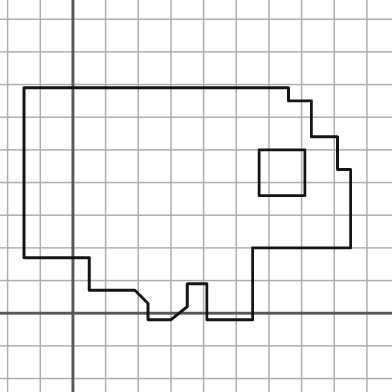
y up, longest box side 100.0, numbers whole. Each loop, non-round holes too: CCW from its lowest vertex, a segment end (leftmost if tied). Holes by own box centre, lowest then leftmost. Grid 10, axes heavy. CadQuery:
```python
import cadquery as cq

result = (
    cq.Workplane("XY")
    .moveTo(23.0, -2.0)
    .lineTo(30.0, -2.0)
    .lineTo(35.0, 2.0)
    .lineTo(35.0, 9.0)
    .lineTo(41.0, 9.0)
    .lineTo(41.0, -2.0)
    .lineTo(55.0, -2.0)
    .lineTo(55.0, 20.0)
    .lineTo(85.0, 20.0)
    .lineTo(85.0, 44.0)
    .lineTo(81.0, 44.0)
    .lineTo(81.0, 54.0)
    .lineTo(73.0, 54.0)
    .lineTo(73.0, 65.0)
    .lineTo(66.0, 65.0)
    .lineTo(66.0, 69.0)
    .lineTo(-15.0, 69.0)
    .lineTo(-15.0, 17.0)
    .lineTo(5.0, 17.0)
    .lineTo(5.0, 7.0)
    .lineTo(19.0, 7.0)
    .lineTo(23.0, 3.0)
    .close()
    .moveTo(57.0, 36.0)
    .lineTo(71.0, 36.0)
    .lineTo(71.0, 50.0)
    .lineTo(57.0, 50.0)
    .close()
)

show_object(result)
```